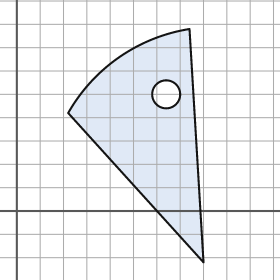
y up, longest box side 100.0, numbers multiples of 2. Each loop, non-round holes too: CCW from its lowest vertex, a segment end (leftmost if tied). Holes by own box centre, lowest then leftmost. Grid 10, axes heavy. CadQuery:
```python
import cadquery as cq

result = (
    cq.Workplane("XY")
    .moveTo(80.0, -22.0)
    .lineTo(74.0, 78.0)
    .threePointArc((44.0, 66.0), (22.0, 42.0))
    .close()
    .moveTo(64.0, 50.0)
    .circle(6.0)
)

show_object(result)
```